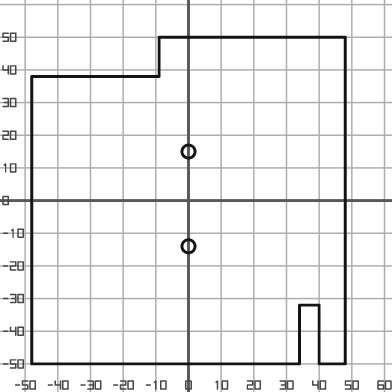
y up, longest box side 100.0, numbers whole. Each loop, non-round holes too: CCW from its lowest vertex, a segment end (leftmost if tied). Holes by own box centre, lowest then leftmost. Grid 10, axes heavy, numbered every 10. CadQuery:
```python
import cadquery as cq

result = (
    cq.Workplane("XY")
    .moveTo(-48.0, -50.0)
    .lineTo(34.0, -50.0)
    .lineTo(34.0, -32.0)
    .lineTo(40.0, -32.0)
    .lineTo(40.0, -50.0)
    .lineTo(48.0, -50.0)
    .lineTo(48.0, 50.0)
    .lineTo(-9.0, 50.0)
    .lineTo(-9.0, 38.0)
    .lineTo(-48.0, 38.0)
    .close()
    .moveTo(0.0, -14.0)
    .circle(2.0)
    .moveTo(0.0, 15.0)
    .circle(2.0)
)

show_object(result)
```